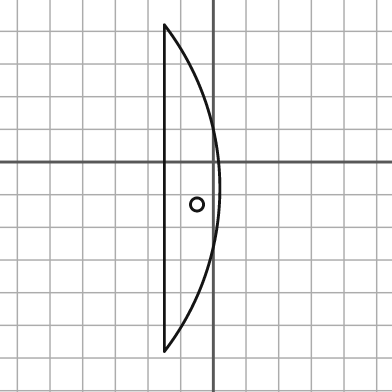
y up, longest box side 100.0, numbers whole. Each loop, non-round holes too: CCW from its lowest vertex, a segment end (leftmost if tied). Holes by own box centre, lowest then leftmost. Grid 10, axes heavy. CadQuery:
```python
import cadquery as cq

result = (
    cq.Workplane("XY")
    .moveTo(-15.0, -58.0)
    .threePointArc((2.0, -8.0), (-15.0, 42.0))
    .close()
    .moveTo(-5.0, -13.0)
    .circle(2.0)
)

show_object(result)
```